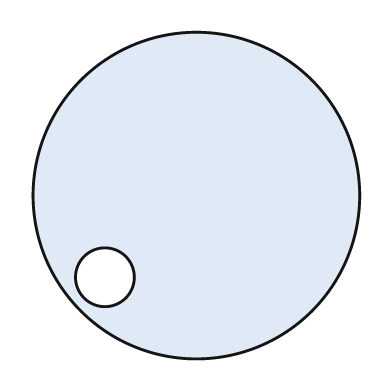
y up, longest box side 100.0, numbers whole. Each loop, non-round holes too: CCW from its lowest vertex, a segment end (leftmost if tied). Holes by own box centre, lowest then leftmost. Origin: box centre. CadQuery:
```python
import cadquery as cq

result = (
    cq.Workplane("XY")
    .moveTo(0.0, 0.0)
    .circle(50.0)
    .moveTo(-28.0, -25.0)
    .circle(9.0)
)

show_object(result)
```